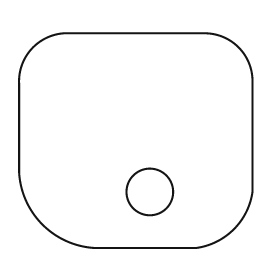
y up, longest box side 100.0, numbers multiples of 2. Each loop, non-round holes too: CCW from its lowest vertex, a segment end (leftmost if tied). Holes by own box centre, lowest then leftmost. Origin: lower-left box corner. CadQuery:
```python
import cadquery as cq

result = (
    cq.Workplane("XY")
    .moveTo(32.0, 0.0)
    .lineTo(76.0, 0.0)
    .threePointArc((92.0, 8.0), (100.0, 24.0))
    .lineTo(100.0, 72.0)
    .threePointArc((94.0, 86.0), (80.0, 92.0))
    .lineTo(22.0, 92.0)
    .threePointArc((6.0, 86.0), (0.0, 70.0))
    .lineTo(0.0, 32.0)
    .threePointArc((10.0, 10.0), (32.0, 0.0))
    .close()
    .moveTo(56.0, 24.0)
    .circle(10.0)
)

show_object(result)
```